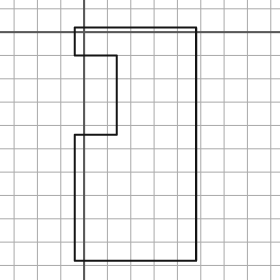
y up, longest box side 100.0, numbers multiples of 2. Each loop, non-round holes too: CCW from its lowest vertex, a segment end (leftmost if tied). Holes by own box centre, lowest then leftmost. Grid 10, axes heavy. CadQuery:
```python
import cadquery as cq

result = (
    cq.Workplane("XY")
    .moveTo(-4.0, -98.0)
    .lineTo(48.0, -98.0)
    .lineTo(48.0, 2.0)
    .lineTo(-4.0, 2.0)
    .lineTo(-4.0, -10.0)
    .lineTo(14.0, -10.0)
    .lineTo(14.0, -44.0)
    .lineTo(-4.0, -44.0)
    .close()
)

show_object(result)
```